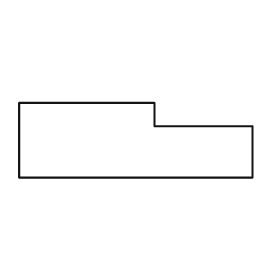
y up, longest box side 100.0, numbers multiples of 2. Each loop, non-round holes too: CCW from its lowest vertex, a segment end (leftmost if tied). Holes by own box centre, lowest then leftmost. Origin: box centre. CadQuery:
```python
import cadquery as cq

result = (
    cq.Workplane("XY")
    .moveTo(-50.0, -16.0)
    .lineTo(50.0, -16.0)
    .lineTo(50.0, 6.0)
    .lineTo(8.0, 6.0)
    .lineTo(8.0, 16.0)
    .lineTo(-50.0, 16.0)
    .close()
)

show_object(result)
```